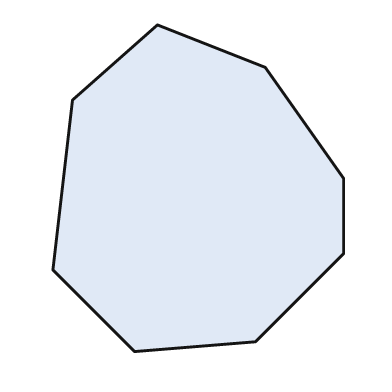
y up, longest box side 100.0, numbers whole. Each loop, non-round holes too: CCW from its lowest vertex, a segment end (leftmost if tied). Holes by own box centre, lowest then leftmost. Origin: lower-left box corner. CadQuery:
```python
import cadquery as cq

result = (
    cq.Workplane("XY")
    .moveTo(25.0, 0.0)
    .lineTo(62.0, 3.0)
    .lineTo(89.0, 30.0)
    .lineTo(89.0, 53.0)
    .lineTo(65.0, 87.0)
    .lineTo(32.0, 100.0)
    .lineTo(6.0, 77.0)
    .lineTo(0.0, 25.0)
    .close()
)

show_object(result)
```